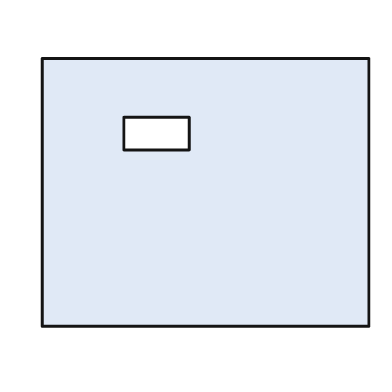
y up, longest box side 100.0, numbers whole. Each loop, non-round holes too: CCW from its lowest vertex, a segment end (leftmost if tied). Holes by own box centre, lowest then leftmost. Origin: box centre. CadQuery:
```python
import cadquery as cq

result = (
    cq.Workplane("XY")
    .moveTo(-50.0, -41.0)
    .lineTo(50.0, -41.0)
    .lineTo(50.0, 41.0)
    .lineTo(-50.0, 41.0)
    .close()
    .moveTo(-25.0, 13.0)
    .lineTo(-5.0, 13.0)
    .lineTo(-5.0, 23.0)
    .lineTo(-25.0, 23.0)
    .close()
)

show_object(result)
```